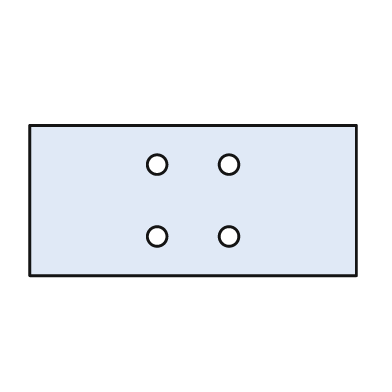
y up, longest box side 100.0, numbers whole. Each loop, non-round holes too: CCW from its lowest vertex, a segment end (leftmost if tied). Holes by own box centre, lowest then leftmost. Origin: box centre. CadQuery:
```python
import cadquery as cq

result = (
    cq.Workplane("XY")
    .moveTo(-50.0, -23.0)
    .lineTo(50.0, -23.0)
    .lineTo(50.0, 23.0)
    .lineTo(-50.0, 23.0)
    .close()
    .moveTo(-11.0, -11.0)
    .circle(3.0)
    .moveTo(11.0, -11.0)
    .circle(3.0)
    .moveTo(-11.0, 11.0)
    .circle(3.0)
    .moveTo(11.0, 11.0)
    .circle(3.0)
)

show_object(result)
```